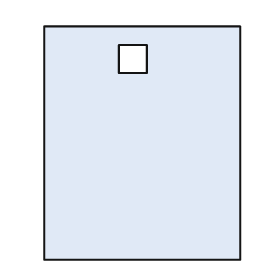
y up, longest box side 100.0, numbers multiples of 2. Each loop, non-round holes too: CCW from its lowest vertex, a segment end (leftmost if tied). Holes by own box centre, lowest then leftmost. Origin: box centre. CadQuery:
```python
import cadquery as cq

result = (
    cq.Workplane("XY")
    .moveTo(-42.0, -50.0)
    .lineTo(42.0, -50.0)
    .lineTo(42.0, 50.0)
    .lineTo(-42.0, 50.0)
    .close()
    .moveTo(-10.0, 30.0)
    .lineTo(2.0, 30.0)
    .lineTo(2.0, 42.0)
    .lineTo(-10.0, 42.0)
    .close()
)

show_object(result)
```